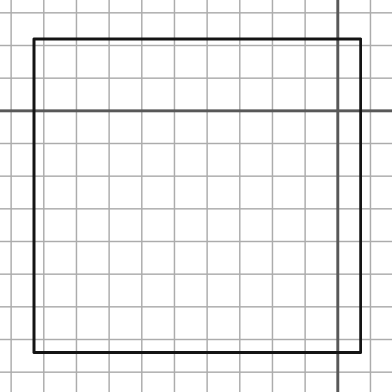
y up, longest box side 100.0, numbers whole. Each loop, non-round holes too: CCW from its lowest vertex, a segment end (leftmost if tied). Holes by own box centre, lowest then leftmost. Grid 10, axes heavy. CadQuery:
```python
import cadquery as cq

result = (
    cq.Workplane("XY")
    .moveTo(-93.0, -74.0)
    .lineTo(7.0, -74.0)
    .lineTo(7.0, 22.0)
    .lineTo(-93.0, 22.0)
    .close()
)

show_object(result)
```